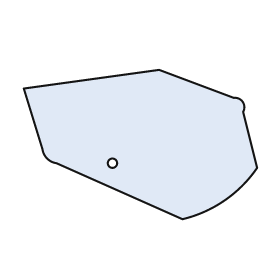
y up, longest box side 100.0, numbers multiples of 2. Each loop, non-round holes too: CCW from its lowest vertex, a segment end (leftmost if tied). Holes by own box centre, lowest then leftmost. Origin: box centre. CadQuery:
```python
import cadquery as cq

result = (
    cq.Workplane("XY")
    .moveTo(18.0, -32.0)
    .threePointArc((36.0, -24.0), (50.0, -10.0))
    .lineTo(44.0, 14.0)
    .threePointArc((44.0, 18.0), (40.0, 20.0))
    .lineTo(8.0, 32.0)
    .lineTo(-50.0, 24.0)
    .lineTo(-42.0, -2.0)
    .threePointArc((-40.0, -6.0), (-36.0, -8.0))
    .close()
    .moveTo(-12.0, -8.0)
    .circle(2.0)
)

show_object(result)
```